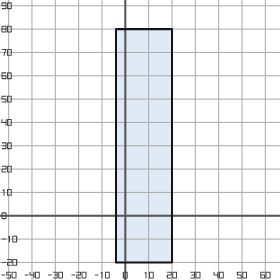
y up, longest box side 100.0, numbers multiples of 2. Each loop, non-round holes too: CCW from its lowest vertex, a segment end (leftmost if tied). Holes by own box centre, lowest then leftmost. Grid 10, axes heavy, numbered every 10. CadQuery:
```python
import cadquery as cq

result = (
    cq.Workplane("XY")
    .moveTo(-4.0, -20.0)
    .lineTo(20.0, -20.0)
    .lineTo(20.0, 80.0)
    .lineTo(-4.0, 80.0)
    .close()
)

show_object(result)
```